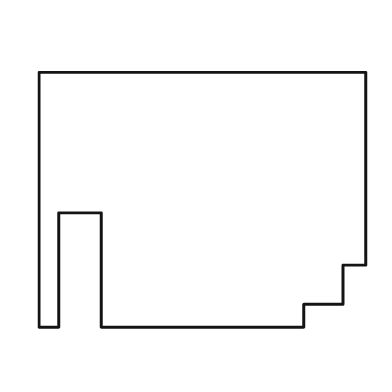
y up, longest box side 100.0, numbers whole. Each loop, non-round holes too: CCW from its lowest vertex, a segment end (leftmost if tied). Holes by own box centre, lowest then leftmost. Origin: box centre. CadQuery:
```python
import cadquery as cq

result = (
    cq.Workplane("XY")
    .moveTo(-50.0, -39.0)
    .lineTo(-44.0, -39.0)
    .lineTo(-44.0, -4.0)
    .lineTo(-31.0, -4.0)
    .lineTo(-31.0, -39.0)
    .lineTo(31.0, -39.0)
    .lineTo(31.0, -32.0)
    .lineTo(43.0, -32.0)
    .lineTo(43.0, -20.0)
    .lineTo(50.0, -20.0)
    .lineTo(50.0, 39.0)
    .lineTo(-50.0, 39.0)
    .close()
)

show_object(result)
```